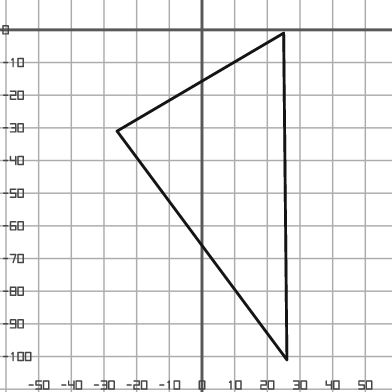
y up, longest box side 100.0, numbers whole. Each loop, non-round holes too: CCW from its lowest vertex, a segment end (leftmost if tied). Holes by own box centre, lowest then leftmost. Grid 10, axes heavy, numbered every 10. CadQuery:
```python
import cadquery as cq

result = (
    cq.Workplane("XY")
    .moveTo(26.0, -101.0)
    .lineTo(25.0, -1.0)
    .lineTo(-26.0, -31.0)
    .close()
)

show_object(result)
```